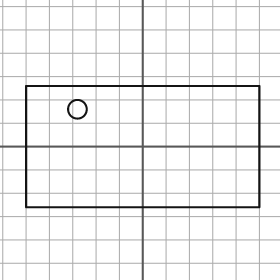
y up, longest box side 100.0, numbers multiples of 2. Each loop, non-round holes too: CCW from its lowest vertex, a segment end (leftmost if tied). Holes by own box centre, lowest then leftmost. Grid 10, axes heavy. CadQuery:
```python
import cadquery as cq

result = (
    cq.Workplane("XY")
    .moveTo(-50.0, -26.0)
    .lineTo(50.0, -26.0)
    .lineTo(50.0, 26.0)
    .lineTo(-50.0, 26.0)
    .close()
    .moveTo(-28.0, 16.0)
    .circle(4.0)
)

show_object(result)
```